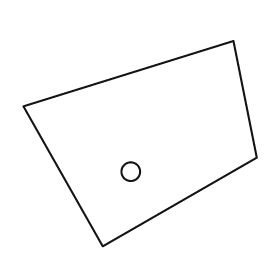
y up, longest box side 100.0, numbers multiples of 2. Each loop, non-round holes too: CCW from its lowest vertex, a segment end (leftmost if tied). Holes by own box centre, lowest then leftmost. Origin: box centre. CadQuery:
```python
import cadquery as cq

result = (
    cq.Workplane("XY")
    .moveTo(-16.0, -44.0)
    .lineTo(50.0, -6.0)
    .lineTo(40.0, 44.0)
    .lineTo(-50.0, 16.0)
    .close()
    .moveTo(-4.0, -12.0)
    .circle(4.0)
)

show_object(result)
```